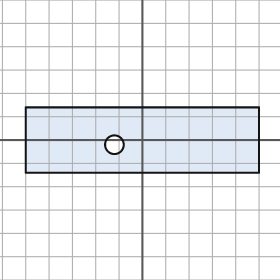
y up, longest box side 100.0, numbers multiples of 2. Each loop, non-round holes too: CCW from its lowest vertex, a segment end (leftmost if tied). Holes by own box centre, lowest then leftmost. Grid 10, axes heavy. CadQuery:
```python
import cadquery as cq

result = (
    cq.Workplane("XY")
    .moveTo(-50.0, -14.0)
    .lineTo(50.0, -14.0)
    .lineTo(50.0, 14.0)
    .lineTo(-50.0, 14.0)
    .close()
    .moveTo(-12.0, -2.0)
    .circle(4.0)
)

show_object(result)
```